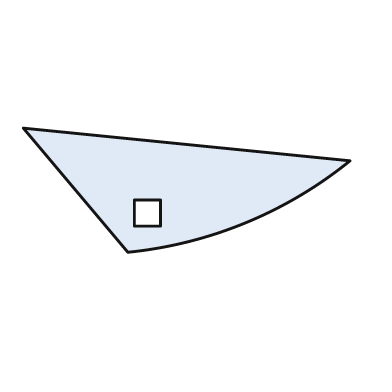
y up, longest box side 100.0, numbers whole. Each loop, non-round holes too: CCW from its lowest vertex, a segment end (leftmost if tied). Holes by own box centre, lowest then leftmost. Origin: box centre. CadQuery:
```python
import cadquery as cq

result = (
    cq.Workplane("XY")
    .moveTo(-18.0, -19.0)
    .threePointArc((18.0, -10.0), (50.0, 9.0))
    .lineTo(-50.0, 19.0)
    .close()
    .moveTo(-16.0, -11.0)
    .lineTo(-8.0, -11.0)
    .lineTo(-8.0, -3.0)
    .lineTo(-16.0, -3.0)
    .close()
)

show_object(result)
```